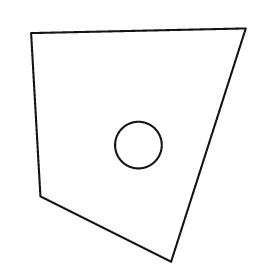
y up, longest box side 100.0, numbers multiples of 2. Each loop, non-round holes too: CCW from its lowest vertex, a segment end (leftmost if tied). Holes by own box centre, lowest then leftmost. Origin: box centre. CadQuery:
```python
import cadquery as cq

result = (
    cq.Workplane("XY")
    .moveTo(14.0, -50.0)
    .lineTo(46.0, 50.0)
    .lineTo(-46.0, 48.0)
    .lineTo(-42.0, -22.0)
    .close()
    .moveTo(0.0, 0.0)
    .circle(10.0)
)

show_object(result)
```